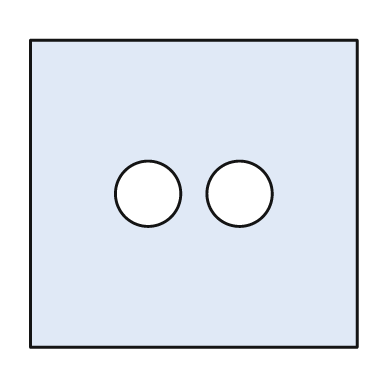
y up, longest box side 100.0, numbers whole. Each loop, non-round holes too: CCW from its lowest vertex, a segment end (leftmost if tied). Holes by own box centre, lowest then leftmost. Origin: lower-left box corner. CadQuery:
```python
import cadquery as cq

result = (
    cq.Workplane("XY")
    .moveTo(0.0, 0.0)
    .lineTo(100.0, 0.0)
    .lineTo(100.0, 94.0)
    .lineTo(0.0, 94.0)
    .close()
    .moveTo(36.0, 47.0)
    .circle(10.0)
    .moveTo(64.0, 47.0)
    .circle(10.0)
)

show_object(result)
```